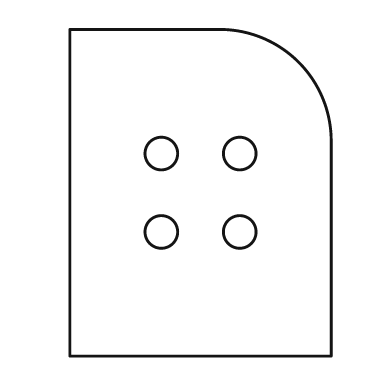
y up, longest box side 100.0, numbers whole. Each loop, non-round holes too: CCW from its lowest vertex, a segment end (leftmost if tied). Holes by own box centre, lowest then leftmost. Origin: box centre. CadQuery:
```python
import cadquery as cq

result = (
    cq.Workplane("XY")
    .moveTo(-40.0, -50.0)
    .lineTo(40.0, -50.0)
    .lineTo(40.0, 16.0)
    .threePointArc((30.0, 40.0), (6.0, 50.0))
    .lineTo(-40.0, 50.0)
    .close()
    .moveTo(-12.0, -12.0)
    .circle(5.0)
    .moveTo(12.0, -12.0)
    .circle(5.0)
    .moveTo(-12.0, 12.0)
    .circle(5.0)
    .moveTo(12.0, 12.0)
    .circle(5.0)
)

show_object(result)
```